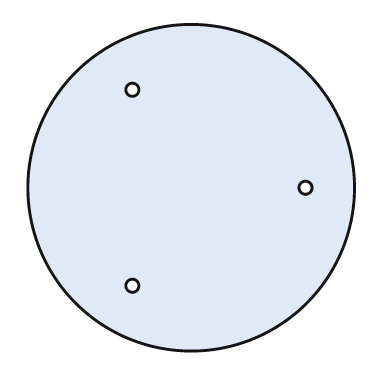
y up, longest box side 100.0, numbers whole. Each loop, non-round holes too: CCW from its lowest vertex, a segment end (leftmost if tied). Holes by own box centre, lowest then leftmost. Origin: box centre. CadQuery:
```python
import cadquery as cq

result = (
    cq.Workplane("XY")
    .moveTo(0.0, 0.0)
    .circle(50.0)
    .moveTo(-18.0, -30.0)
    .circle(2.0)
    .moveTo(35.0, 0.0)
    .circle(2.0)
    .moveTo(-18.0, 30.0)
    .circle(2.0)
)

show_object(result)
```